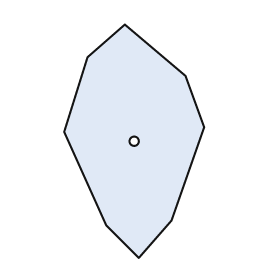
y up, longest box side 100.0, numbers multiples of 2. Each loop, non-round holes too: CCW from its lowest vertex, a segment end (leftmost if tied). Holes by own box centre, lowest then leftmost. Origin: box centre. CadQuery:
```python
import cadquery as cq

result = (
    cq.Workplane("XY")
    .moveTo(2.0, -50.0)
    .lineTo(16.0, -34.0)
    .lineTo(30.0, 6.0)
    .lineTo(22.0, 28.0)
    .lineTo(-4.0, 50.0)
    .lineTo(-20.0, 36.0)
    .lineTo(-30.0, 4.0)
    .lineTo(-12.0, -36.0)
    .close()
    .moveTo(0.0, 0.0)
    .circle(2.0)
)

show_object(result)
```